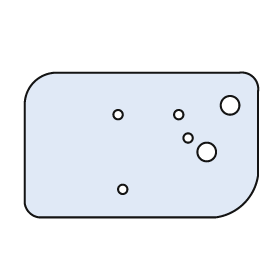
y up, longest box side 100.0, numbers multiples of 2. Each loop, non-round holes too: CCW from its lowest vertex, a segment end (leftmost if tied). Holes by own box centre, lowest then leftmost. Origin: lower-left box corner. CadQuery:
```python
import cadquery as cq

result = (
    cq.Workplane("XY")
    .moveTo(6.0, 0.0)
    .lineTo(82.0, 0.0)
    .threePointArc((94.0, 6.0), (100.0, 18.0))
    .lineTo(100.0, 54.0)
    .threePointArc((98.0, 60.0), (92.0, 62.0))
    .lineTo(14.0, 62.0)
    .threePointArc((4.0, 58.0), (0.0, 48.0))
    .lineTo(0.0, 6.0)
    .threePointArc((2.0, 2.0), (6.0, 0.0))
    .close()
    .moveTo(42.0, 12.0)
    .circle(2.0)
    .moveTo(78.0, 28.0)
    .circle(4.0)
    .moveTo(70.0, 34.0)
    .circle(2.0)
    .moveTo(40.0, 44.0)
    .circle(2.0)
    .moveTo(66.0, 44.0)
    .circle(2.0)
    .moveTo(88.0, 48.0)
    .circle(4.0)
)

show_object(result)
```